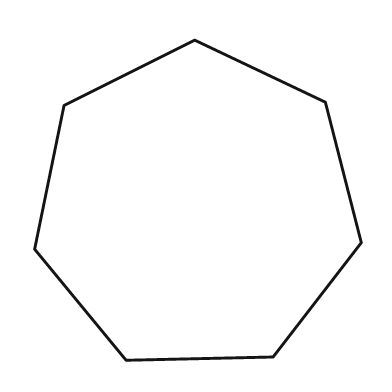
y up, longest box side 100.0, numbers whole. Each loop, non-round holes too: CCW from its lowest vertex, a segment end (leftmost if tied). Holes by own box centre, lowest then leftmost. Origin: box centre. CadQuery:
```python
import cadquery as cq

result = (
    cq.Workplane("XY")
    .moveTo(-22.0, -49.0)
    .lineTo(23.0, -48.0)
    .lineTo(50.0, -13.0)
    .lineTo(39.0, 30.0)
    .lineTo(-1.0, 49.0)
    .lineTo(-41.0, 29.0)
    .lineTo(-50.0, -15.0)
    .close()
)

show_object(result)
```